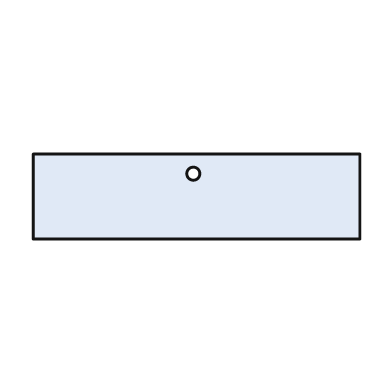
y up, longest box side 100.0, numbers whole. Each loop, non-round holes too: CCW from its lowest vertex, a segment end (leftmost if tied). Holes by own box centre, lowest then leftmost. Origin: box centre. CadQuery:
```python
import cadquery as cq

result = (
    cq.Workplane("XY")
    .moveTo(-50.0, -13.0)
    .lineTo(50.0, -13.0)
    .lineTo(50.0, 13.0)
    .lineTo(-50.0, 13.0)
    .close()
    .moveTo(-1.0, 7.0)
    .circle(2.0)
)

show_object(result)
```